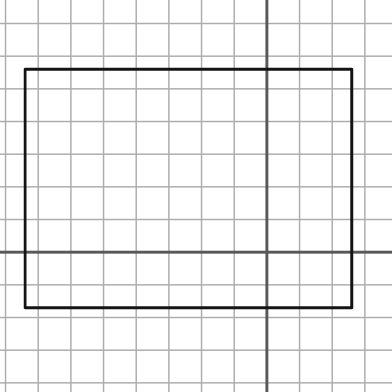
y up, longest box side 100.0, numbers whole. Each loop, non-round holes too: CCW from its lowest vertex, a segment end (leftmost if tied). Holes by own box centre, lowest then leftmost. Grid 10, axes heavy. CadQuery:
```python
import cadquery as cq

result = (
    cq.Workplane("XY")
    .moveTo(-74.0, -17.0)
    .lineTo(26.0, -17.0)
    .lineTo(26.0, 56.0)
    .lineTo(-74.0, 56.0)
    .close()
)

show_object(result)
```